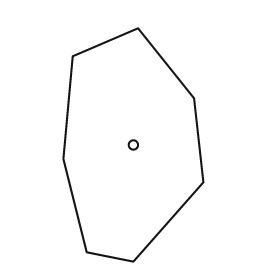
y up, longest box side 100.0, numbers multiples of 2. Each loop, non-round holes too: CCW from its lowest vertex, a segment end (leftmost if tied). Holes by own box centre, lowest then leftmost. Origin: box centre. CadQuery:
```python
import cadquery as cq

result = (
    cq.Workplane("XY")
    .moveTo(0.0, -50.0)
    .lineTo(30.0, -16.0)
    .lineTo(26.0, 20.0)
    .lineTo(2.0, 50.0)
    .lineTo(-26.0, 38.0)
    .lineTo(-30.0, -6.0)
    .lineTo(-20.0, -46.0)
    .close()
    .moveTo(0.0, 0.0)
    .circle(2.0)
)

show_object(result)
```